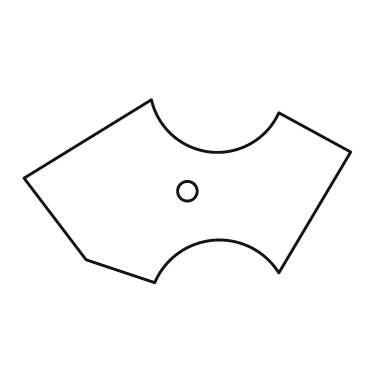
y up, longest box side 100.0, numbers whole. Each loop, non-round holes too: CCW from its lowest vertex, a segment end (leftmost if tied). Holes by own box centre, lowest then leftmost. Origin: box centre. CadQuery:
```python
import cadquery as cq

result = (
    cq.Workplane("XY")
    .moveTo(-10.0, -28.0)
    .threePointArc((8.0, -15.0), (28.0, -25.0))
    .lineTo(50.0, 12.0)
    .lineTo(28.0, 24.0)
    .threePointArc((7.0, 12.0), (-11.0, 28.0))
    .lineTo(-50.0, 4.0)
    .lineTo(-31.0, -21.0)
    .close()
    .moveTo(0.0, 0.0)
    .circle(3.0)
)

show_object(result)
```